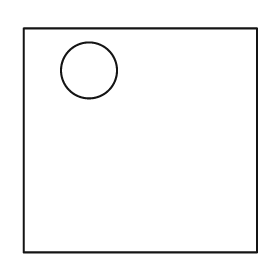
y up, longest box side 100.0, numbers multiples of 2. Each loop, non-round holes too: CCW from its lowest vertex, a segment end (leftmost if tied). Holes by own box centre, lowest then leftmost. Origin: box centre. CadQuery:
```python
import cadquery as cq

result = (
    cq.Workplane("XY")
    .moveTo(-50.0, -48.0)
    .lineTo(50.0, -48.0)
    .lineTo(50.0, 48.0)
    .lineTo(-50.0, 48.0)
    .close()
    .moveTo(-22.0, 30.0)
    .circle(12.0)
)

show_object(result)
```